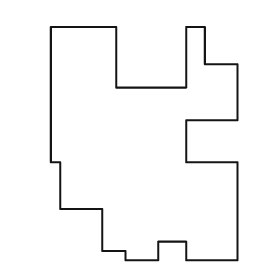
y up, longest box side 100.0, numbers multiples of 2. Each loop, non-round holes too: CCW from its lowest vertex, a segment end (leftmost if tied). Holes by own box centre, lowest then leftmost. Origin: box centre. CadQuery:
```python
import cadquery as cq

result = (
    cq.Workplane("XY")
    .moveTo(-8.0, -50.0)
    .lineTo(6.0, -50.0)
    .lineTo(6.0, -42.0)
    .lineTo(18.0, -42.0)
    .lineTo(18.0, -50.0)
    .lineTo(40.0, -50.0)
    .lineTo(40.0, -8.0)
    .lineTo(18.0, -8.0)
    .lineTo(18.0, 10.0)
    .lineTo(40.0, 10.0)
    .lineTo(40.0, 34.0)
    .lineTo(26.0, 34.0)
    .lineTo(26.0, 50.0)
    .lineTo(18.0, 50.0)
    .lineTo(18.0, 24.0)
    .lineTo(-12.0, 24.0)
    .lineTo(-12.0, 50.0)
    .lineTo(-40.0, 50.0)
    .lineTo(-40.0, -8.0)
    .lineTo(-36.0, -8.0)
    .lineTo(-36.0, -28.0)
    .lineTo(-18.0, -28.0)
    .lineTo(-18.0, -46.0)
    .lineTo(-8.0, -46.0)
    .close()
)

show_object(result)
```